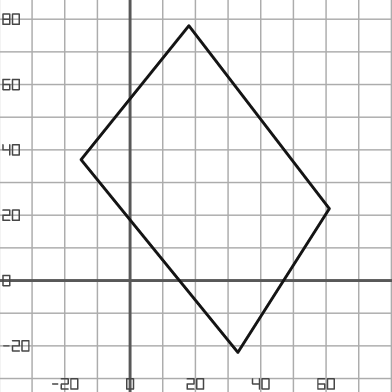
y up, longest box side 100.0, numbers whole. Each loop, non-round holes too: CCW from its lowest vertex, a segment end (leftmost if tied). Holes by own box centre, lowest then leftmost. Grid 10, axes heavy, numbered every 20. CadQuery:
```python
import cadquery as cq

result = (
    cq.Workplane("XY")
    .moveTo(33.0, -22.0)
    .lineTo(61.0, 22.0)
    .lineTo(18.0, 78.0)
    .lineTo(-15.0, 37.0)
    .close()
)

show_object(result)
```